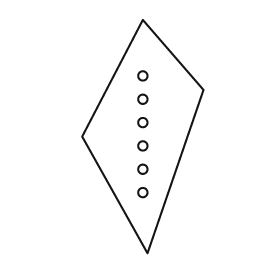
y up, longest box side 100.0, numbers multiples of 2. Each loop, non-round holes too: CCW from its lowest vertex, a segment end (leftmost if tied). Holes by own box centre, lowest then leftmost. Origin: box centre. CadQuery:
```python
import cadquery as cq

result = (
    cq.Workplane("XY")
    .moveTo(2.0, -50.0)
    .lineTo(26.0, 20.0)
    .lineTo(0.0, 50.0)
    .lineTo(-26.0, 0.0)
    .close()
    .moveTo(0.0, -24.0)
    .circle(2.0)
    .moveTo(0.0, -14.0)
    .circle(2.0)
    .moveTo(0.0, -4.0)
    .circle(2.0)
    .moveTo(0.0, 6.0)
    .circle(2.0)
    .moveTo(0.0, 16.0)
    .circle(2.0)
    .moveTo(0.0, 26.0)
    .circle(2.0)
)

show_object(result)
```